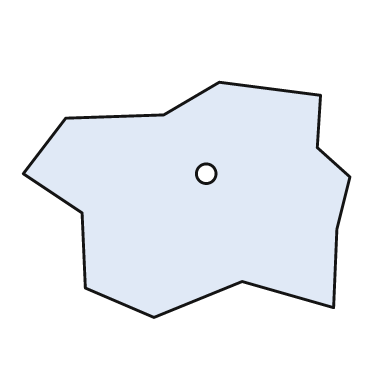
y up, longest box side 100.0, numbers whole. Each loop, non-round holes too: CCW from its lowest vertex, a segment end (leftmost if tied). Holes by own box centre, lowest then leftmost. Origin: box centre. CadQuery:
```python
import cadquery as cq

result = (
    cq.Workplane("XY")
    .moveTo(-10.0, -36.0)
    .lineTo(17.0, -25.0)
    .lineTo(45.0, -33.0)
    .lineTo(46.0, -9.0)
    .lineTo(50.0, 7.0)
    .lineTo(40.0, 16.0)
    .lineTo(41.0, 32.0)
    .lineTo(10.0, 36.0)
    .lineTo(-7.0, 26.0)
    .lineTo(-37.0, 25.0)
    .lineTo(-50.0, 8.0)
    .lineTo(-32.0, -4.0)
    .lineTo(-31.0, -27.0)
    .close()
    .moveTo(6.0, 8.0)
    .circle(3.0)
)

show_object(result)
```